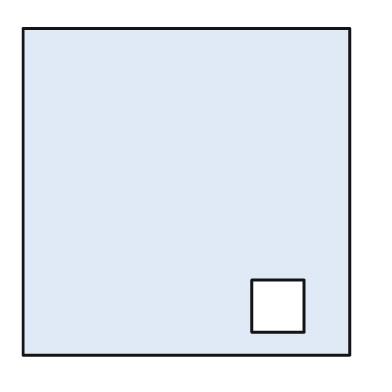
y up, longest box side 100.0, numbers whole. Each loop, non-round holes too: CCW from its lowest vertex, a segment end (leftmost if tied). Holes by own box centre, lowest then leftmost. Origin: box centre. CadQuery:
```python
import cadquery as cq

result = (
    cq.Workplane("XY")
    .moveTo(-50.0, -50.0)
    .lineTo(50.0, -50.0)
    .lineTo(50.0, 50.0)
    .lineTo(-50.0, 50.0)
    .close()
    .moveTo(20.0, -43.0)
    .lineTo(36.0, -43.0)
    .lineTo(36.0, -27.0)
    .lineTo(20.0, -27.0)
    .close()
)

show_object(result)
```